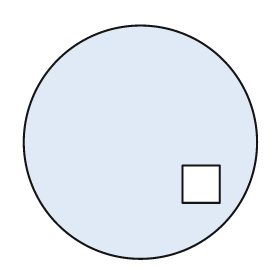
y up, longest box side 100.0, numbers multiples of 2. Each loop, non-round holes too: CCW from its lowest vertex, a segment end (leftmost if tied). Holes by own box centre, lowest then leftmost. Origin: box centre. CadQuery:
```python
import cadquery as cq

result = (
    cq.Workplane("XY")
    .moveTo(0.0, 0.0)
    .circle(50.0)
    .moveTo(18.0, -26.0)
    .lineTo(34.0, -26.0)
    .lineTo(34.0, -10.0)
    .lineTo(18.0, -10.0)
    .close()
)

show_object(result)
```